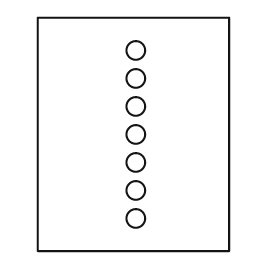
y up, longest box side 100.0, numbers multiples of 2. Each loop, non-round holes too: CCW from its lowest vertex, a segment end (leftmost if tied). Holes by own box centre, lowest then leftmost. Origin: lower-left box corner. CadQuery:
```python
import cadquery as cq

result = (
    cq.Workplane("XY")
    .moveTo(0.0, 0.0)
    .lineTo(82.0, 0.0)
    .lineTo(82.0, 100.0)
    .lineTo(0.0, 100.0)
    .close()
    .moveTo(42.0, 14.0)
    .circle(4.0)
    .moveTo(42.0, 26.0)
    .circle(4.0)
    .moveTo(42.0, 38.0)
    .circle(4.0)
    .moveTo(42.0, 50.0)
    .circle(4.0)
    .moveTo(42.0, 62.0)
    .circle(4.0)
    .moveTo(42.0, 74.0)
    .circle(4.0)
    .moveTo(42.0, 86.0)
    .circle(4.0)
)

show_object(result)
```